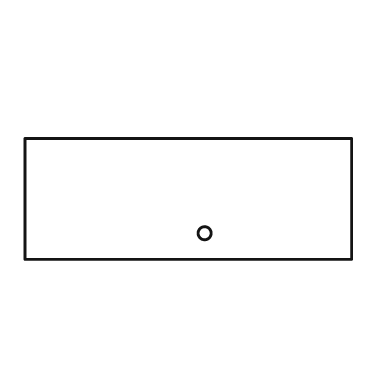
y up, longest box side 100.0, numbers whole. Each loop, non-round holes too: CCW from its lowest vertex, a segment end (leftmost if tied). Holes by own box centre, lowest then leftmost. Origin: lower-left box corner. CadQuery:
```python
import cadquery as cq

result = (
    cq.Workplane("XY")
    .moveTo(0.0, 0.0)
    .lineTo(100.0, 0.0)
    .lineTo(100.0, 37.0)
    .lineTo(0.0, 37.0)
    .close()
    .moveTo(55.0, 8.0)
    .circle(2.0)
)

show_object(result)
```